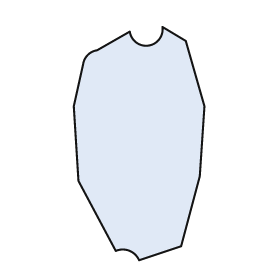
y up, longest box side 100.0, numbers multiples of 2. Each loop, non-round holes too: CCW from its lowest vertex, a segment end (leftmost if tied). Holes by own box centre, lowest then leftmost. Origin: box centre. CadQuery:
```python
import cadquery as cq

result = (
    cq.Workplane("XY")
    .moveTo(0.0, -50.0)
    .lineTo(18.0, -44.0)
    .lineTo(26.0, -14.0)
    .lineTo(28.0, 16.0)
    .lineTo(20.0, 44.0)
    .lineTo(10.0, 50.0)
    .threePointArc((4.0, 42.0), (-4.0, 48.0))
    .lineTo(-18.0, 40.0)
    .threePointArc((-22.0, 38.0), (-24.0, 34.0))
    .lineTo(-28.0, 16.0)
    .lineTo(-26.0, -16.0)
    .lineTo(-10.0, -46.0)
    .threePointArc((-4.0, -46.0), (0.0, -50.0))
    .close()
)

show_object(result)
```